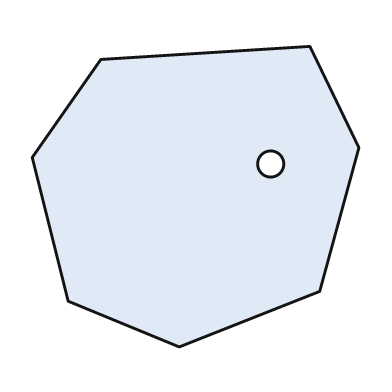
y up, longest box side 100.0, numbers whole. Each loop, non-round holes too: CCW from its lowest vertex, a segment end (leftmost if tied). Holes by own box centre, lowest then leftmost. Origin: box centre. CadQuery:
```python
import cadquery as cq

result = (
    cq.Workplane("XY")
    .moveTo(-5.0, -46.0)
    .lineTo(38.0, -29.0)
    .lineTo(50.0, 15.0)
    .lineTo(35.0, 46.0)
    .lineTo(-29.0, 42.0)
    .lineTo(-50.0, 12.0)
    .lineTo(-39.0, -32.0)
    .close()
    .moveTo(23.0, 10.0)
    .circle(4.0)
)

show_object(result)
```